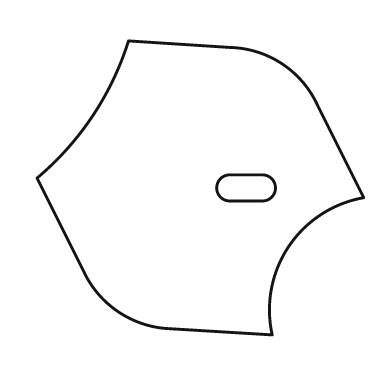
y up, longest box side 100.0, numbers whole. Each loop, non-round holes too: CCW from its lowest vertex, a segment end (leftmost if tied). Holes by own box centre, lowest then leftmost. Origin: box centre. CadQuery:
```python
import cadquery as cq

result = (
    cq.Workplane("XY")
    .moveTo(22.0, -45.0)
    .threePointArc((27.0, -18.0), (50.0, -3.0))
    .lineTo(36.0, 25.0)
    .threePointArc((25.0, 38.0), (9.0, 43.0))
    .lineTo(-22.0, 45.0)
    .threePointArc((-33.0, 22.0), (-50.0, 3.0))
    .lineTo(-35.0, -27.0)
    .threePointArc((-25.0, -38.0), (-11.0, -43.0))
    .close()
    .moveTo(9.0, -4.0)
    .lineTo(19.0, -4.0)
    .threePointArc((23.0, 0.0), (19.0, 4.0))
    .lineTo(9.0, 4.0)
    .threePointArc((5.0, 0.0), (9.0, -4.0))
    .close()
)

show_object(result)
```